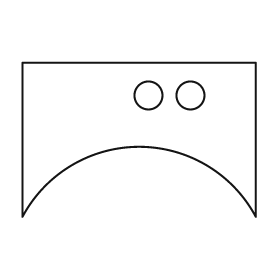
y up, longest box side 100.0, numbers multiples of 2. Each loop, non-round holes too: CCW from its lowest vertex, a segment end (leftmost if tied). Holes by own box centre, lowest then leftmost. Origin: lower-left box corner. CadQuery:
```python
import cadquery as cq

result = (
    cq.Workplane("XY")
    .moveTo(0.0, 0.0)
    .threePointArc((50.0, 30.0), (100.0, 0.0))
    .lineTo(100.0, 66.0)
    .lineTo(0.0, 66.0)
    .close()
    .moveTo(54.0, 52.0)
    .circle(6.0)
    .moveTo(72.0, 52.0)
    .circle(6.0)
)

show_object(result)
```